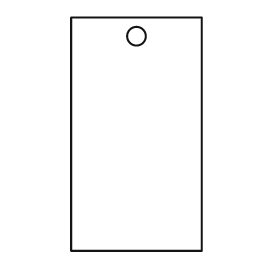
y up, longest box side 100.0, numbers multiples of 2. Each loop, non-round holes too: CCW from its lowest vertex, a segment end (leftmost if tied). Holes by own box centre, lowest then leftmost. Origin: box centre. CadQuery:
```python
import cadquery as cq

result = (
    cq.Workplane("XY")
    .moveTo(-28.0, -50.0)
    .lineTo(28.0, -50.0)
    .lineTo(28.0, 50.0)
    .lineTo(-28.0, 50.0)
    .close()
    .moveTo(0.0, 42.0)
    .circle(4.0)
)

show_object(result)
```